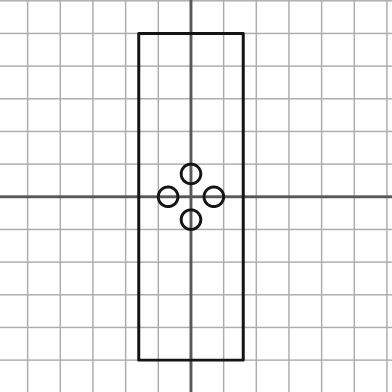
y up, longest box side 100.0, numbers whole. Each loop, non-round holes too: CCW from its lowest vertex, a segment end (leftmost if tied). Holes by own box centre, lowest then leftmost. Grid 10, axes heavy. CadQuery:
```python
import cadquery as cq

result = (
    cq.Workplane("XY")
    .moveTo(-16.0, -50.0)
    .lineTo(16.0, -50.0)
    .lineTo(16.0, 50.0)
    .lineTo(-16.0, 50.0)
    .close()
    .moveTo(0.0, -7.0)
    .circle(3.0)
    .moveTo(-7.0, 0.0)
    .circle(3.0)
    .moveTo(7.0, 0.0)
    .circle(3.0)
    .moveTo(0.0, 7.0)
    .circle(3.0)
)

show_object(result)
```